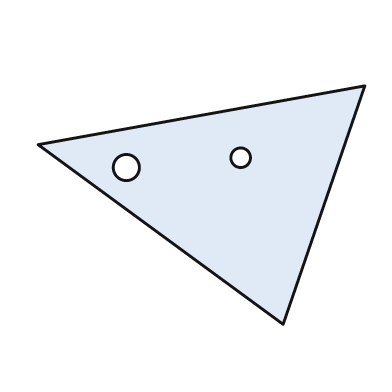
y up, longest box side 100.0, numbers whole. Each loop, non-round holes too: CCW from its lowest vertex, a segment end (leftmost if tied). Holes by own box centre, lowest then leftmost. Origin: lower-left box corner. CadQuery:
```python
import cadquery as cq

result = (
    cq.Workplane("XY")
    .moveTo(75.0, 0.0)
    .lineTo(100.0, 73.0)
    .lineTo(0.0, 55.0)
    .close()
    .moveTo(27.0, 48.0)
    .circle(4.0)
    .moveTo(62.0, 51.0)
    .circle(3.0)
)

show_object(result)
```